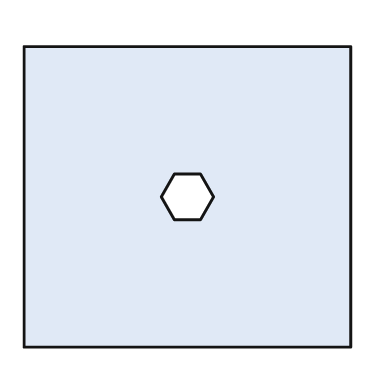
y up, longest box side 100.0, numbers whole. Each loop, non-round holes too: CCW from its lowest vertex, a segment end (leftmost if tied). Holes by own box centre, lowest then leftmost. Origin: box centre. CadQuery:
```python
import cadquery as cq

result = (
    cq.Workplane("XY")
    .moveTo(-50.0, -46.0)
    .lineTo(50.0, -46.0)
    .lineTo(50.0, 46.0)
    .lineTo(-50.0, 46.0)
    .close()
    .moveTo(-4.0, -7.0)
    .lineTo(4.0, -7.0)
    .lineTo(8.0, 0.0)
    .lineTo(4.0, 7.0)
    .lineTo(-4.0, 7.0)
    .lineTo(-8.0, 0.0)
    .close()
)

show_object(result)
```